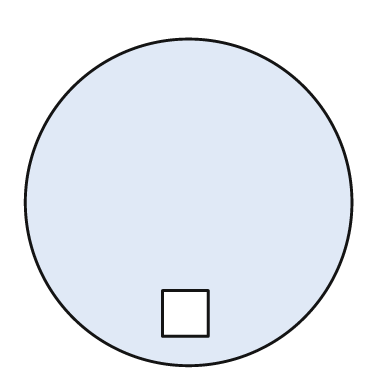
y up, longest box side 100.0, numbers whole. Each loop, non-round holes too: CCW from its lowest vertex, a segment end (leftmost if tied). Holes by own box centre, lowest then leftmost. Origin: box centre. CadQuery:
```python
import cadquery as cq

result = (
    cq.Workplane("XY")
    .moveTo(0.0, 0.0)
    .circle(50.0)
    .moveTo(-8.0, -41.0)
    .lineTo(6.0, -41.0)
    .lineTo(6.0, -27.0)
    .lineTo(-8.0, -27.0)
    .close()
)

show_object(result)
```